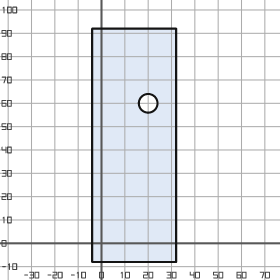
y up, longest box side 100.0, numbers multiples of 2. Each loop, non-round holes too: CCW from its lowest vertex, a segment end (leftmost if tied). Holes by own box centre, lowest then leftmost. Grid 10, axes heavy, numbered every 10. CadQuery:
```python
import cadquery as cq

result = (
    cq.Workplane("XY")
    .moveTo(-4.0, -8.0)
    .lineTo(32.0, -8.0)
    .lineTo(32.0, 92.0)
    .lineTo(-4.0, 92.0)
    .close()
    .moveTo(20.0, 60.0)
    .circle(4.0)
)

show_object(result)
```